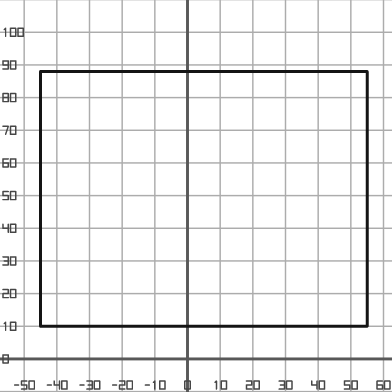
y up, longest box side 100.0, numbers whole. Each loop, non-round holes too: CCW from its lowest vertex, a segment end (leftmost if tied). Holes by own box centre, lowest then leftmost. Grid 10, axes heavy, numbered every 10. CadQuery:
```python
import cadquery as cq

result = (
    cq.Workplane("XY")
    .moveTo(-45.0, 10.0)
    .lineTo(55.0, 10.0)
    .lineTo(55.0, 88.0)
    .lineTo(-45.0, 88.0)
    .close()
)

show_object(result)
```